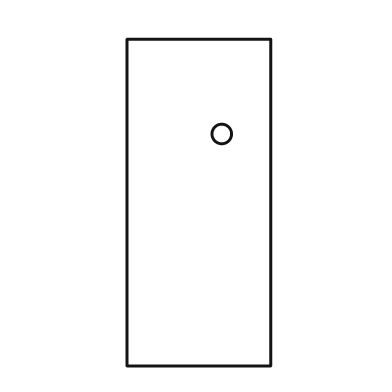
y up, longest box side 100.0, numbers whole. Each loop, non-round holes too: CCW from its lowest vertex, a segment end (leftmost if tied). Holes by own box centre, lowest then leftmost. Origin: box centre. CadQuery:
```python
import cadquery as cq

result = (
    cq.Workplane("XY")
    .moveTo(-22.0, -50.0)
    .lineTo(22.0, -50.0)
    .lineTo(22.0, 50.0)
    .lineTo(-22.0, 50.0)
    .close()
    .moveTo(7.0, 21.0)
    .circle(3.0)
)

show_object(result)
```